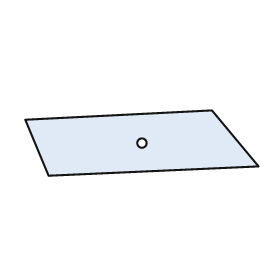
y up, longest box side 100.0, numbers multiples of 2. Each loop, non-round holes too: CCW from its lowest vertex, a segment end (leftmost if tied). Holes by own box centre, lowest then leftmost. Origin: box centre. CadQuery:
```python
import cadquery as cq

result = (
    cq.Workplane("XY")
    .moveTo(-40.0, -14.0)
    .lineTo(50.0, -10.0)
    .lineTo(30.0, 14.0)
    .lineTo(-50.0, 10.0)
    .close()
    .moveTo(0.0, 0.0)
    .circle(2.0)
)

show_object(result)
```